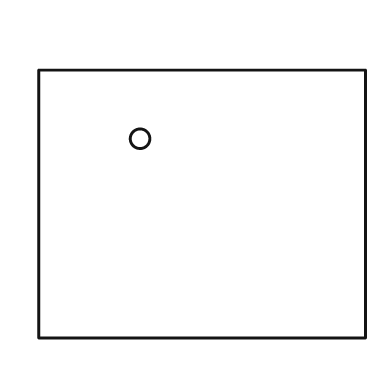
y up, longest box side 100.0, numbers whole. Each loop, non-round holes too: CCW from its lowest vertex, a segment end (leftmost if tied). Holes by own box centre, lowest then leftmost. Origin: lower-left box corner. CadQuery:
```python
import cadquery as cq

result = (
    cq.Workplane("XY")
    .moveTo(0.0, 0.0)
    .lineTo(100.0, 0.0)
    .lineTo(100.0, 82.0)
    .lineTo(0.0, 82.0)
    .close()
    .moveTo(31.0, 61.0)
    .circle(3.0)
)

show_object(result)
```